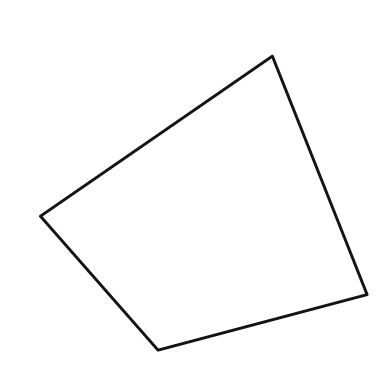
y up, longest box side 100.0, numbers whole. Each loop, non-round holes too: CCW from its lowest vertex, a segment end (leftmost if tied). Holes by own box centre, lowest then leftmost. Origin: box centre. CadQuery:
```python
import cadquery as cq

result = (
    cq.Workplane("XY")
    .moveTo(-14.0, -45.0)
    .lineTo(50.0, -28.0)
    .lineTo(21.0, 45.0)
    .lineTo(-50.0, -4.0)
    .close()
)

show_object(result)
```